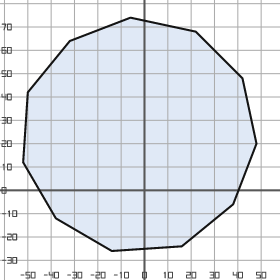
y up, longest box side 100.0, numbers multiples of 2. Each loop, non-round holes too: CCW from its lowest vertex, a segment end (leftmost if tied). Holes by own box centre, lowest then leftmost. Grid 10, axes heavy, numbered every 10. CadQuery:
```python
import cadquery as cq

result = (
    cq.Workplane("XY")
    .moveTo(-14.0, -26.0)
    .lineTo(16.0, -24.0)
    .lineTo(38.0, -6.0)
    .lineTo(48.0, 20.0)
    .lineTo(42.0, 48.0)
    .lineTo(22.0, 68.0)
    .lineTo(-6.0, 74.0)
    .lineTo(-32.0, 64.0)
    .lineTo(-50.0, 42.0)
    .lineTo(-52.0, 12.0)
    .lineTo(-38.0, -12.0)
    .close()
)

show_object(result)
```